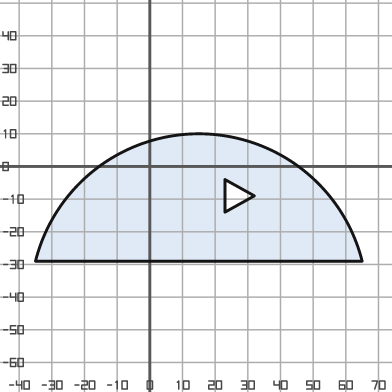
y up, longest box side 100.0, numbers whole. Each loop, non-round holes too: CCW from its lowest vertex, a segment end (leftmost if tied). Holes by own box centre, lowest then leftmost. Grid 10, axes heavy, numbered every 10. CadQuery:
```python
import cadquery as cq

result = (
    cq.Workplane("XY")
    .moveTo(-35.0, -29.0)
    .lineTo(65.0, -29.0)
    .threePointArc((15.0, 10.0), (-35.0, -29.0))
    .close()
    .moveTo(23.0, -14.0)
    .lineTo(32.0, -9.0)
    .lineTo(23.0, -4.0)
    .close()
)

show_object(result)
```